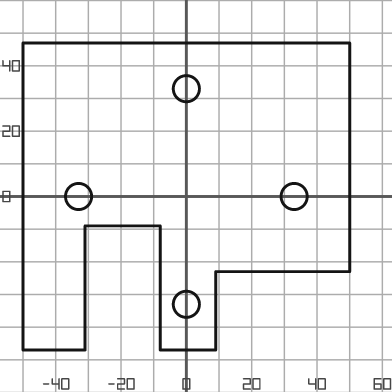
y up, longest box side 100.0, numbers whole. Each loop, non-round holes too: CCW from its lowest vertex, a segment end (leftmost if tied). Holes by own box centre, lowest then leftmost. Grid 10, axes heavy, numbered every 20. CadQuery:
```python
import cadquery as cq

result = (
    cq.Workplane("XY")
    .moveTo(-50.0, -47.0)
    .lineTo(-31.0, -47.0)
    .lineTo(-31.0, -9.0)
    .lineTo(-8.0, -9.0)
    .lineTo(-8.0, -47.0)
    .lineTo(9.0, -47.0)
    .lineTo(9.0, -23.0)
    .lineTo(50.0, -23.0)
    .lineTo(50.0, 47.0)
    .lineTo(-50.0, 47.0)
    .close()
    .moveTo(0.0, -33.0)
    .circle(4.0)
    .moveTo(-33.0, 0.0)
    .circle(4.0)
    .moveTo(33.0, 0.0)
    .circle(4.0)
    .moveTo(0.0, 33.0)
    .circle(4.0)
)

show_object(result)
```